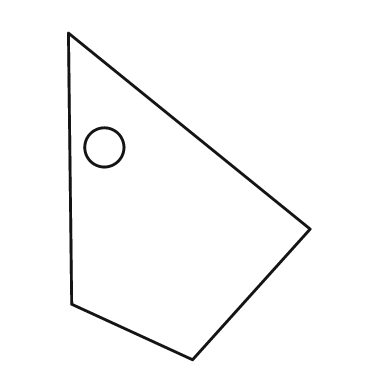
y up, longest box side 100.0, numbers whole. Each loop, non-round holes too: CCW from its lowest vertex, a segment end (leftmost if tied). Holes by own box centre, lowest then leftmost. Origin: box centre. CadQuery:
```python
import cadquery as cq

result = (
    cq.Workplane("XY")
    .moveTo(1.0, -50.0)
    .lineTo(37.0, -10.0)
    .lineTo(-37.0, 50.0)
    .lineTo(-36.0, -33.0)
    .close()
    .moveTo(-26.0, 15.0)
    .circle(6.0)
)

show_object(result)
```